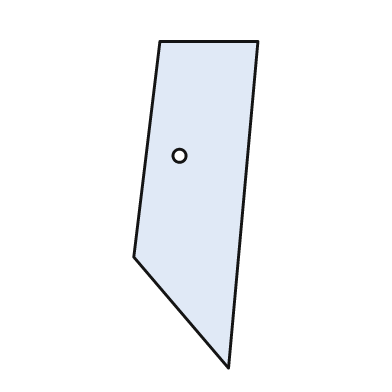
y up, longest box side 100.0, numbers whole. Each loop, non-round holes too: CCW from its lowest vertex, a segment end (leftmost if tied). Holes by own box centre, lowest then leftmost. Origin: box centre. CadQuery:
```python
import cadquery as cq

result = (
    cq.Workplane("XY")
    .moveTo(10.0, -50.0)
    .lineTo(19.0, 50.0)
    .lineTo(-11.0, 50.0)
    .lineTo(-19.0, -16.0)
    .close()
    .moveTo(-5.0, 15.0)
    .circle(2.0)
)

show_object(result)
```